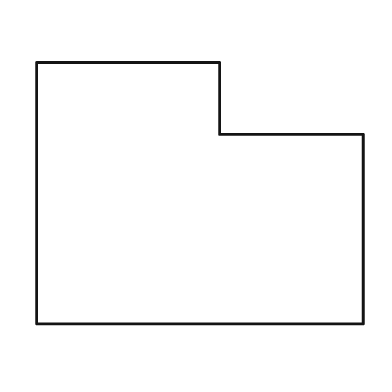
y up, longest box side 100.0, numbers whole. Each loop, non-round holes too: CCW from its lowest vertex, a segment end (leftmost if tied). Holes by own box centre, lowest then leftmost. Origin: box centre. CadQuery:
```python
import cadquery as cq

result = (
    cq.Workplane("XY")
    .moveTo(-50.0, -40.0)
    .lineTo(50.0, -40.0)
    .lineTo(50.0, 18.0)
    .lineTo(6.0, 18.0)
    .lineTo(6.0, 40.0)
    .lineTo(-50.0, 40.0)
    .close()
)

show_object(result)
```